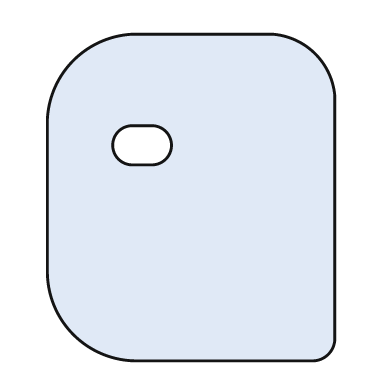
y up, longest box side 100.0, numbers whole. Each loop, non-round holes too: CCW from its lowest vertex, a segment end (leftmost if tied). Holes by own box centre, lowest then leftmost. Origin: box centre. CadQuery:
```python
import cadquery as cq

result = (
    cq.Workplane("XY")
    .moveTo(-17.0, -50.0)
    .lineTo(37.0, -50.0)
    .threePointArc((42.0, -48.0), (44.0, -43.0))
    .lineTo(44.0, 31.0)
    .threePointArc((38.0, 44.0), (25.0, 50.0))
    .lineTo(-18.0, 50.0)
    .threePointArc((-36.0, 42.0), (-44.0, 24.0))
    .lineTo(-44.0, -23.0)
    .threePointArc((-36.0, -42.0), (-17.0, -50.0))
    .close()
    .moveTo(-18.0, 10.0)
    .lineTo(-12.0, 10.0)
    .threePointArc((-6.0, 16.0), (-12.0, 22.0))
    .lineTo(-18.0, 22.0)
    .threePointArc((-24.0, 16.0), (-18.0, 10.0))
    .close()
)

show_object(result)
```